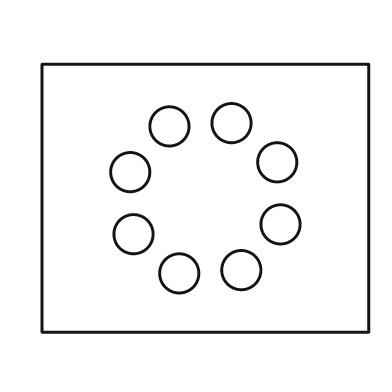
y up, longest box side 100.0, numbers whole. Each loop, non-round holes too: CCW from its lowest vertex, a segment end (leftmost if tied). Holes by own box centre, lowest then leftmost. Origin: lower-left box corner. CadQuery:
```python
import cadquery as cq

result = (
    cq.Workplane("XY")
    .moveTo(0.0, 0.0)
    .lineTo(100.0, 0.0)
    .lineTo(100.0, 82.0)
    .lineTo(0.0, 82.0)
    .close()
    .moveTo(42.0, 18.0)
    .circle(6.0)
    .moveTo(61.0, 19.0)
    .circle(6.0)
    .moveTo(28.0, 30.0)
    .circle(6.0)
    .moveTo(73.0, 33.0)
    .circle(6.0)
    .moveTo(27.0, 49.0)
    .circle(6.0)
    .moveTo(72.0, 52.0)
    .circle(6.0)
    .moveTo(39.0, 63.0)
    .circle(6.0)
    .moveTo(58.0, 64.0)
    .circle(6.0)
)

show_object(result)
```